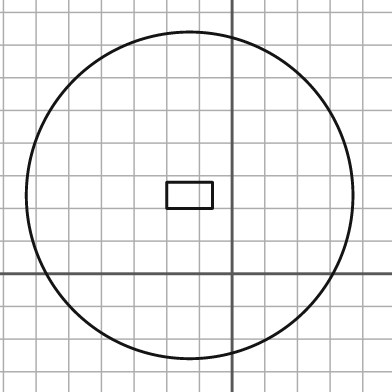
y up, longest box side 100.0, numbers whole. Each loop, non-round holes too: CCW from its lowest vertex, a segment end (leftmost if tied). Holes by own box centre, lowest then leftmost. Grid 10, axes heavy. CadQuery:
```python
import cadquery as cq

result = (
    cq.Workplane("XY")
    .moveTo(-13.0, 24.0)
    .circle(50.0)
    .moveTo(-20.0, 20.0)
    .lineTo(-6.0, 20.0)
    .lineTo(-6.0, 28.0)
    .lineTo(-20.0, 28.0)
    .close()
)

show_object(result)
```